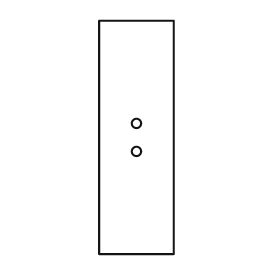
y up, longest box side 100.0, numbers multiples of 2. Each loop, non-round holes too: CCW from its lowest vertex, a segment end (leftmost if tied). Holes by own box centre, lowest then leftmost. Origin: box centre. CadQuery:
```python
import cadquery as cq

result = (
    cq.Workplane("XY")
    .moveTo(-16.0, -50.0)
    .lineTo(16.0, -50.0)
    .lineTo(16.0, 50.0)
    .lineTo(-16.0, 50.0)
    .close()
    .moveTo(0.0, -6.0)
    .circle(2.0)
    .moveTo(0.0, 6.0)
    .circle(2.0)
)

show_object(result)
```